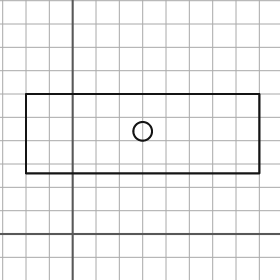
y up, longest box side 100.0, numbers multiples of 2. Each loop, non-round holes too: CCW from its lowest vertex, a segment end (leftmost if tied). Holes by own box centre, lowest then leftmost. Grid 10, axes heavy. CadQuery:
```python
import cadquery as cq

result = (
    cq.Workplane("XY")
    .moveTo(-20.0, 26.0)
    .lineTo(80.0, 26.0)
    .lineTo(80.0, 60.0)
    .lineTo(-20.0, 60.0)
    .close()
    .moveTo(30.0, 44.0)
    .circle(4.0)
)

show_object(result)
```